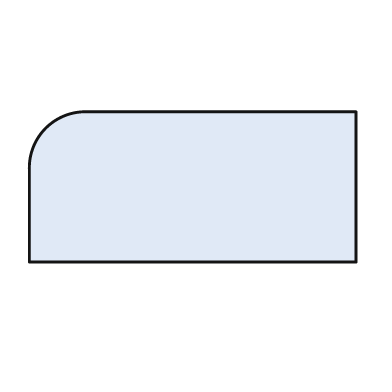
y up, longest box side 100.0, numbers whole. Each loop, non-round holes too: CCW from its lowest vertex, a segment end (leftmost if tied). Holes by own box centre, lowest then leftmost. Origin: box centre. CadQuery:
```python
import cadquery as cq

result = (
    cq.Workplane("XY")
    .moveTo(-50.0, -23.0)
    .lineTo(50.0, -23.0)
    .lineTo(50.0, 23.0)
    .lineTo(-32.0, 23.0)
    .threePointArc((-45.0, 18.0), (-50.0, 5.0))
    .close()
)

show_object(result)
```